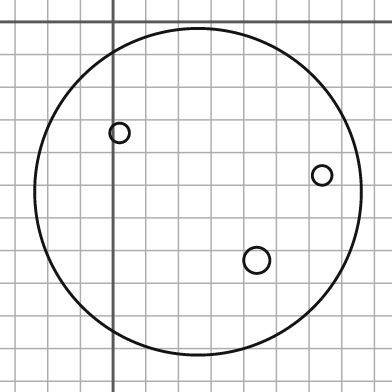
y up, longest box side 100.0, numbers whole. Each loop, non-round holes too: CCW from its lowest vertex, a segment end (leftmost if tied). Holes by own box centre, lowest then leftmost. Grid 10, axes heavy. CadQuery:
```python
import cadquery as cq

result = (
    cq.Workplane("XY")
    .moveTo(26.0, -52.0)
    .circle(50.0)
    .moveTo(44.0, -73.0)
    .circle(4.0)
    .moveTo(64.0, -47.0)
    .circle(3.0)
    .moveTo(2.0, -34.0)
    .circle(3.0)
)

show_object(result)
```